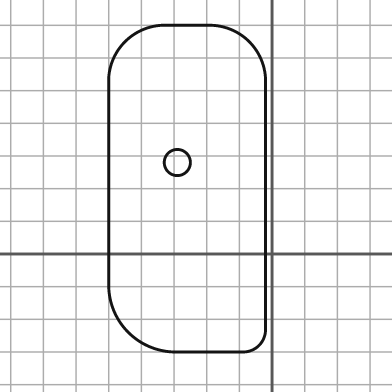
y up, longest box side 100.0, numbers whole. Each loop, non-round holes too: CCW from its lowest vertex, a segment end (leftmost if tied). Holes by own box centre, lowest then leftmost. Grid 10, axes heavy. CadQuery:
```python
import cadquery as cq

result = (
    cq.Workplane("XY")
    .moveTo(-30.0, -30.0)
    .lineTo(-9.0, -30.0)
    .threePointArc((-4.0, -28.0), (-2.0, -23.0))
    .lineTo(-2.0, 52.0)
    .threePointArc((-7.0, 65.0), (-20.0, 70.0))
    .lineTo(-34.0, 70.0)
    .threePointArc((-45.0, 65.0), (-50.0, 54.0))
    .lineTo(-50.0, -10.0)
    .threePointArc((-44.0, -24.0), (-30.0, -30.0))
    .close()
    .moveTo(-29.0, 28.0)
    .circle(4.0)
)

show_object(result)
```